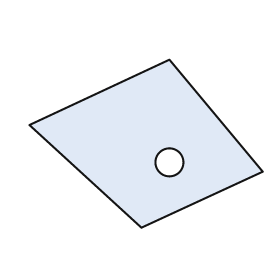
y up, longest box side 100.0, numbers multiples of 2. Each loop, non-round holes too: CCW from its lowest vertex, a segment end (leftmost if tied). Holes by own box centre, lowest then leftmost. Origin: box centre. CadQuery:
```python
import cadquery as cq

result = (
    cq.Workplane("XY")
    .moveTo(-2.0, -36.0)
    .lineTo(50.0, -12.0)
    .lineTo(10.0, 36.0)
    .lineTo(-50.0, 8.0)
    .close()
    .moveTo(10.0, -8.0)
    .circle(6.0)
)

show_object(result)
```